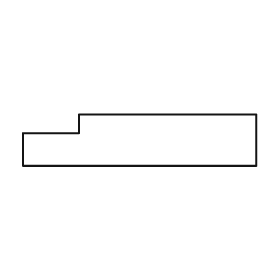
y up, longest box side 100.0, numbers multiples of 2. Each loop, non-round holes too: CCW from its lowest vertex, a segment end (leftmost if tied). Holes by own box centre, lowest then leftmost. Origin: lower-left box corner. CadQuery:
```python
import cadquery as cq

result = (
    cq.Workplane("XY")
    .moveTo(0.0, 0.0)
    .lineTo(100.0, 0.0)
    .lineTo(100.0, 22.0)
    .lineTo(24.0, 22.0)
    .lineTo(24.0, 14.0)
    .lineTo(0.0, 14.0)
    .close()
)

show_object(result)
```